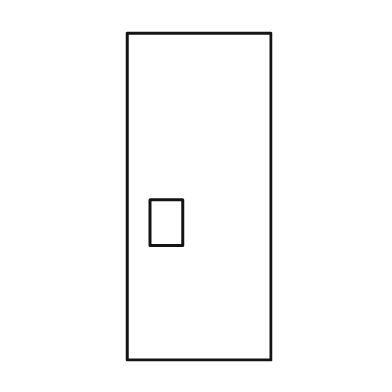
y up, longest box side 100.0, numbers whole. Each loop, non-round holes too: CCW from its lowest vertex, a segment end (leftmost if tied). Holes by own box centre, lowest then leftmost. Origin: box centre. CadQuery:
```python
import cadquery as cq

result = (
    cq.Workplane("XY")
    .moveTo(-22.0, -50.0)
    .lineTo(22.0, -50.0)
    .lineTo(22.0, 50.0)
    .lineTo(-22.0, 50.0)
    .close()
    .moveTo(-15.0, -15.0)
    .lineTo(-5.0, -15.0)
    .lineTo(-5.0, -1.0)
    .lineTo(-15.0, -1.0)
    .close()
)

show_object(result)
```